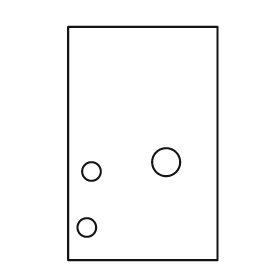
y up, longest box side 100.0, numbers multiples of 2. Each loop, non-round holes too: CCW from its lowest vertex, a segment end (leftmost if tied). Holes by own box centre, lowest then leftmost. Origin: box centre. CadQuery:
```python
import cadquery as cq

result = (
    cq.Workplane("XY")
    .moveTo(-32.0, -50.0)
    .lineTo(32.0, -50.0)
    .lineTo(32.0, 50.0)
    .lineTo(-32.0, 50.0)
    .close()
    .moveTo(-24.0, -36.0)
    .circle(4.0)
    .moveTo(-22.0, -12.0)
    .circle(4.0)
    .moveTo(10.0, -8.0)
    .circle(6.0)
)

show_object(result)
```